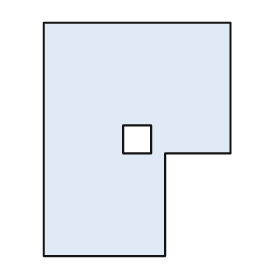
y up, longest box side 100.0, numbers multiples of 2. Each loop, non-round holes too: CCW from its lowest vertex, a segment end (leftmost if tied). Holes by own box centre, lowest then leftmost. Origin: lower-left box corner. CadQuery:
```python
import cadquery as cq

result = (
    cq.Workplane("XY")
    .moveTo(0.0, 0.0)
    .lineTo(52.0, 0.0)
    .lineTo(52.0, 44.0)
    .lineTo(80.0, 44.0)
    .lineTo(80.0, 100.0)
    .lineTo(0.0, 100.0)
    .close()
    .moveTo(34.0, 44.0)
    .lineTo(46.0, 44.0)
    .lineTo(46.0, 56.0)
    .lineTo(34.0, 56.0)
    .close()
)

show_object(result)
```